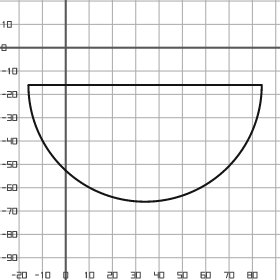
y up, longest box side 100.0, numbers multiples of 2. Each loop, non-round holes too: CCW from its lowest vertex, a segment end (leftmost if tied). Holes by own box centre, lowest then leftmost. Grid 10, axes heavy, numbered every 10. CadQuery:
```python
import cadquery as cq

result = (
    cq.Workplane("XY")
    .moveTo(-16.0, -16.0)
    .threePointArc((34.0, -66.0), (84.0, -16.0))
    .close()
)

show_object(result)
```